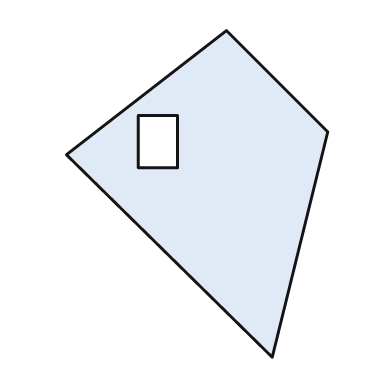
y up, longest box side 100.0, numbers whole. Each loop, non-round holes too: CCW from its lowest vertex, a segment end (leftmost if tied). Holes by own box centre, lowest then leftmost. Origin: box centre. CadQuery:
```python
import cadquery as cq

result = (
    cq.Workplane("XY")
    .moveTo(23.0, -50.0)
    .lineTo(40.0, 19.0)
    .lineTo(9.0, 50.0)
    .lineTo(-40.0, 12.0)
    .close()
    .moveTo(-18.0, 8.0)
    .lineTo(-6.0, 8.0)
    .lineTo(-6.0, 24.0)
    .lineTo(-18.0, 24.0)
    .close()
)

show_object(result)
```